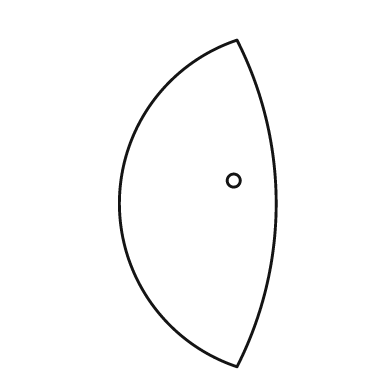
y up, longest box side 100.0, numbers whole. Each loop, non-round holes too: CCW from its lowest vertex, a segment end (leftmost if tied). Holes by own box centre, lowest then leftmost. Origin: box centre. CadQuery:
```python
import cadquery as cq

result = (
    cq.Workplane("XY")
    .moveTo(12.0, -50.0)
    .threePointArc((24.0, 0.0), (12.0, 50.0))
    .threePointArc((-24.0, 0.0), (12.0, -50.0))
    .close()
    .moveTo(11.0, 7.0)
    .circle(2.0)
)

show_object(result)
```